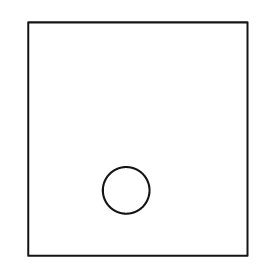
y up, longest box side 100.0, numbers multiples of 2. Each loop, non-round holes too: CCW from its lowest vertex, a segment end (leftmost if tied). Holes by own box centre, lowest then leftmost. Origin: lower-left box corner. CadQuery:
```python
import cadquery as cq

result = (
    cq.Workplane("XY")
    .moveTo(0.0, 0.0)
    .lineTo(94.0, 0.0)
    .lineTo(94.0, 100.0)
    .lineTo(0.0, 100.0)
    .close()
    .moveTo(42.0, 28.0)
    .circle(10.0)
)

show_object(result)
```